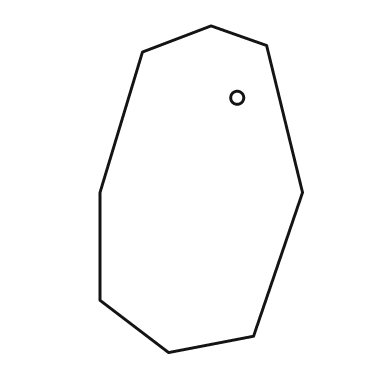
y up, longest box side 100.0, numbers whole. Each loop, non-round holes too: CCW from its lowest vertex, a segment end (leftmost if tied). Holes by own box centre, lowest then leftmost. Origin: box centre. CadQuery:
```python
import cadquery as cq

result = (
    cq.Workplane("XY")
    .moveTo(-10.0, -50.0)
    .lineTo(16.0, -45.0)
    .lineTo(31.0, -1.0)
    .lineTo(20.0, 44.0)
    .lineTo(3.0, 50.0)
    .lineTo(-18.0, 42.0)
    .lineTo(-31.0, -1.0)
    .lineTo(-31.0, -34.0)
    .close()
    .moveTo(11.0, 28.0)
    .circle(2.0)
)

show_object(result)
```